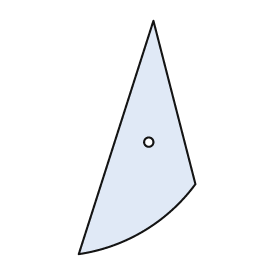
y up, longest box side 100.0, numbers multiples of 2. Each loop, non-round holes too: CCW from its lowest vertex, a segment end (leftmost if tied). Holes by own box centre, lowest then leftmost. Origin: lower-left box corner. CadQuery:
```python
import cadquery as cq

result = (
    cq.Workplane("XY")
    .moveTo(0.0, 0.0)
    .threePointArc((28.0, 10.0), (50.0, 30.0))
    .lineTo(32.0, 100.0)
    .close()
    .moveTo(30.0, 48.0)
    .circle(2.0)
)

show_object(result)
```